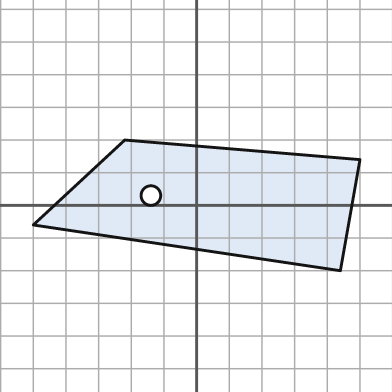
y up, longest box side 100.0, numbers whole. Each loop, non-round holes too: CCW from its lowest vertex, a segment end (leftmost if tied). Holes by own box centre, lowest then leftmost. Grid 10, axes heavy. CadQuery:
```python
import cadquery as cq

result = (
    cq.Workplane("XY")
    .moveTo(44.0, -20.0)
    .lineTo(50.0, 14.0)
    .lineTo(-22.0, 20.0)
    .lineTo(-50.0, -6.0)
    .close()
    .moveTo(-14.0, 3.0)
    .circle(3.0)
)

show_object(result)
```